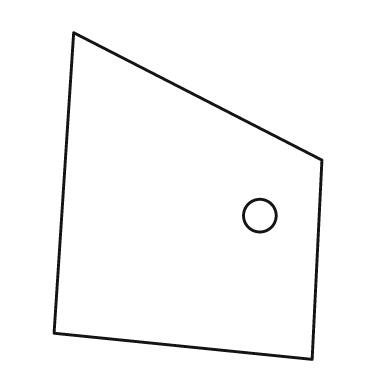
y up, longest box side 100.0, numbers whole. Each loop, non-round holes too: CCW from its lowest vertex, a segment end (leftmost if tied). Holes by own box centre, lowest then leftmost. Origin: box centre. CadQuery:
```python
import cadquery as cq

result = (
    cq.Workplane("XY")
    .moveTo(38.0, -50.0)
    .lineTo(41.0, 11.0)
    .lineTo(-35.0, 50.0)
    .lineTo(-41.0, -42.0)
    .close()
    .moveTo(22.0, -6.0)
    .circle(5.0)
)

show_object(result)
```